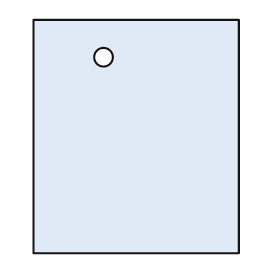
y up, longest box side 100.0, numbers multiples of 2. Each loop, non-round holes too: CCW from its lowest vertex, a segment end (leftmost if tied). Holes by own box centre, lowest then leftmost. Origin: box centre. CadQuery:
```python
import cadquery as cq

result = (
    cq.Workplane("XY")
    .moveTo(-44.0, -50.0)
    .lineTo(44.0, -50.0)
    .lineTo(44.0, 50.0)
    .lineTo(-44.0, 50.0)
    .close()
    .moveTo(-14.0, 34.0)
    .circle(4.0)
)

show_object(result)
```